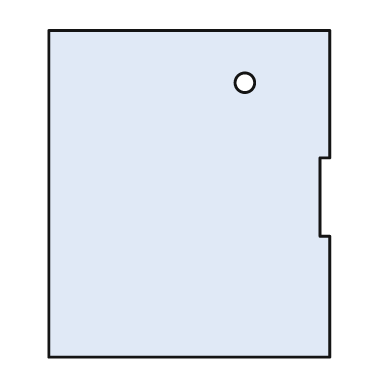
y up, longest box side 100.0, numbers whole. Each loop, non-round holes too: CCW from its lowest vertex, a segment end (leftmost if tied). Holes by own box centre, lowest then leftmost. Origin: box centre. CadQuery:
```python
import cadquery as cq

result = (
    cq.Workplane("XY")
    .moveTo(-43.0, -50.0)
    .lineTo(43.0, -50.0)
    .lineTo(43.0, -13.0)
    .lineTo(40.0, -13.0)
    .lineTo(40.0, 11.0)
    .lineTo(43.0, 11.0)
    .lineTo(43.0, 50.0)
    .lineTo(-43.0, 50.0)
    .close()
    .moveTo(17.0, 34.0)
    .circle(3.0)
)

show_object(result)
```